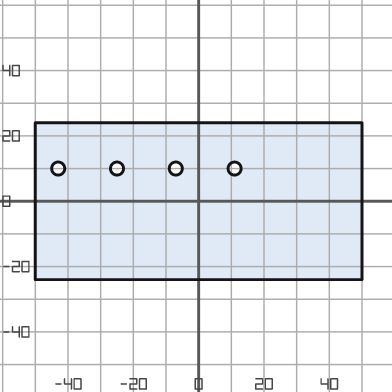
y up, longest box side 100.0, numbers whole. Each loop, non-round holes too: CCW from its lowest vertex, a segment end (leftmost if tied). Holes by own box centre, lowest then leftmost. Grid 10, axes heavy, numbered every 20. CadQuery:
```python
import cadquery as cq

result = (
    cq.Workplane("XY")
    .moveTo(-50.0, -24.0)
    .lineTo(50.0, -24.0)
    .lineTo(50.0, 24.0)
    .lineTo(-50.0, 24.0)
    .close()
    .moveTo(-43.0, 10.0)
    .circle(2.0)
    .moveTo(-25.0, 10.0)
    .circle(2.0)
    .moveTo(-7.0, 10.0)
    .circle(2.0)
    .moveTo(11.0, 10.0)
    .circle(2.0)
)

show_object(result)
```